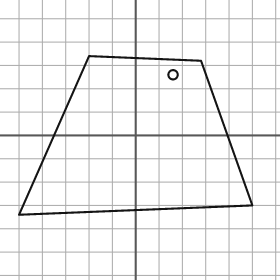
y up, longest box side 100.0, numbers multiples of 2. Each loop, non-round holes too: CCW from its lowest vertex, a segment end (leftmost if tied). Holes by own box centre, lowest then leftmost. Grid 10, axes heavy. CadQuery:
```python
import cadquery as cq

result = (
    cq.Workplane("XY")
    .moveTo(-50.0, -34.0)
    .lineTo(50.0, -30.0)
    .lineTo(28.0, 32.0)
    .lineTo(-20.0, 34.0)
    .close()
    .moveTo(16.0, 26.0)
    .circle(2.0)
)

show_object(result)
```